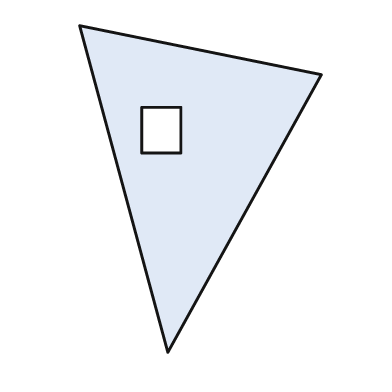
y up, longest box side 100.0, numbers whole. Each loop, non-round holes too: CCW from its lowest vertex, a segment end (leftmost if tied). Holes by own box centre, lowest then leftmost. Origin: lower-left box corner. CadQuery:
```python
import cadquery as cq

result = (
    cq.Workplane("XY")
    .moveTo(27.0, 0.0)
    .lineTo(74.0, 85.0)
    .lineTo(0.0, 100.0)
    .close()
    .moveTo(19.0, 61.0)
    .lineTo(31.0, 61.0)
    .lineTo(31.0, 75.0)
    .lineTo(19.0, 75.0)
    .close()
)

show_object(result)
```